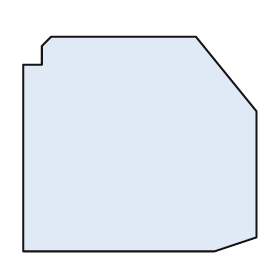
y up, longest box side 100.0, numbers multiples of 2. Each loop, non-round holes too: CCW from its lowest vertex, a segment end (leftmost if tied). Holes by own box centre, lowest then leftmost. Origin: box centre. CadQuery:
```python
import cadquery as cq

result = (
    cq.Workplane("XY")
    .moveTo(-50.0, -46.0)
    .lineTo(32.0, -46.0)
    .lineTo(50.0, -40.0)
    .lineTo(50.0, 14.0)
    .lineTo(24.0, 46.0)
    .lineTo(-38.0, 46.0)
    .lineTo(-42.0, 42.0)
    .lineTo(-42.0, 34.0)
    .lineTo(-50.0, 34.0)
    .close()
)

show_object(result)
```